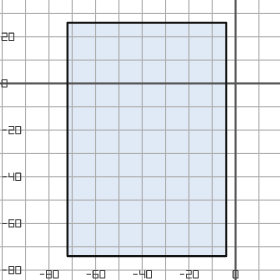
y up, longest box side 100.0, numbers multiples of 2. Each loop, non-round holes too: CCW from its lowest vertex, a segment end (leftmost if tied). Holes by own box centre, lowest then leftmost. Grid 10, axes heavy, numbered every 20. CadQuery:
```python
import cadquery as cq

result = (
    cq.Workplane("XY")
    .moveTo(-72.0, -74.0)
    .lineTo(-4.0, -74.0)
    .lineTo(-4.0, 26.0)
    .lineTo(-72.0, 26.0)
    .close()
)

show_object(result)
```